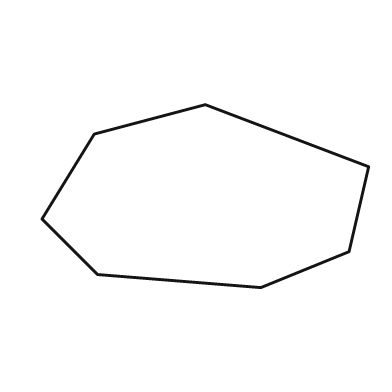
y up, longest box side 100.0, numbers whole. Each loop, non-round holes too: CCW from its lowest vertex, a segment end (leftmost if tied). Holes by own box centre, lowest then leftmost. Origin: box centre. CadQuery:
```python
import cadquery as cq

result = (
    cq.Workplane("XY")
    .moveTo(17.0, -28.0)
    .lineTo(44.0, -17.0)
    .lineTo(50.0, 9.0)
    .lineTo(0.0, 28.0)
    .lineTo(-34.0, 19.0)
    .lineTo(-50.0, -7.0)
    .lineTo(-33.0, -24.0)
    .close()
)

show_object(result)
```